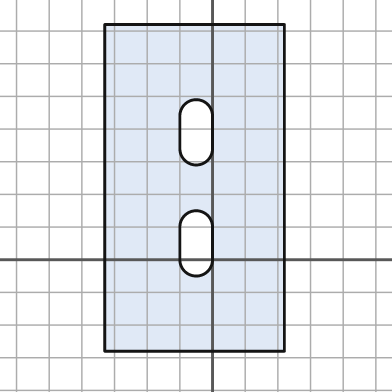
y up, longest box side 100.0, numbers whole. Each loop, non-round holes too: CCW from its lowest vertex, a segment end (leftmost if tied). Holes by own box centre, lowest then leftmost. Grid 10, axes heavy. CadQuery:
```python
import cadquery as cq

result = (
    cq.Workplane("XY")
    .moveTo(-33.0, -28.0)
    .lineTo(22.0, -28.0)
    .lineTo(22.0, 72.0)
    .lineTo(-33.0, 72.0)
    .close()
    .moveTo(-10.0, 0.0)
    .threePointArc((-5.0, -5.0), (0.0, 0.0))
    .lineTo(0.0, 10.0)
    .threePointArc((-5.0, 15.0), (-10.0, 10.0))
    .close()
    .moveTo(-10.0, 34.0)
    .threePointArc((-5.0, 29.0), (0.0, 34.0))
    .lineTo(0.0, 44.0)
    .threePointArc((-5.0, 49.0), (-10.0, 44.0))
    .close()
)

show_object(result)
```